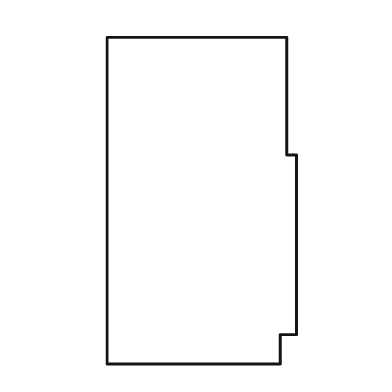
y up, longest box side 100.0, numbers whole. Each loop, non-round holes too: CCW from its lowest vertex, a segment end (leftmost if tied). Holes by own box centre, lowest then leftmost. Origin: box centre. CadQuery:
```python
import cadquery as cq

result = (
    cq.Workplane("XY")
    .moveTo(-29.0, -50.0)
    .lineTo(24.0, -50.0)
    .lineTo(24.0, -41.0)
    .lineTo(29.0, -41.0)
    .lineTo(29.0, 14.0)
    .lineTo(26.0, 14.0)
    .lineTo(26.0, 50.0)
    .lineTo(-29.0, 50.0)
    .close()
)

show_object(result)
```